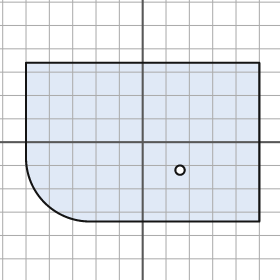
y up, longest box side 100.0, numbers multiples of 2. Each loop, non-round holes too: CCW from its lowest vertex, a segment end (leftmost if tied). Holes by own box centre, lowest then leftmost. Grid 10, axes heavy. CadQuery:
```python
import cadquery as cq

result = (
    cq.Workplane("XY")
    .moveTo(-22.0, -34.0)
    .lineTo(50.0, -34.0)
    .lineTo(50.0, 34.0)
    .lineTo(-50.0, 34.0)
    .lineTo(-50.0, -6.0)
    .threePointArc((-42.0, -26.0), (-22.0, -34.0))
    .close()
    .moveTo(16.0, -12.0)
    .circle(2.0)
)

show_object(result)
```